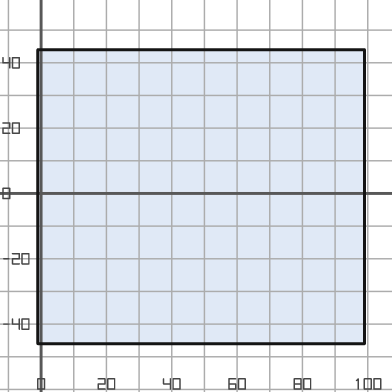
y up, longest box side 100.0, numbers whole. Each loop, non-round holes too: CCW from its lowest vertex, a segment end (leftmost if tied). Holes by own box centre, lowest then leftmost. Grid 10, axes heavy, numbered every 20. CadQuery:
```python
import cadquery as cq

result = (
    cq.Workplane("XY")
    .moveTo(-1.0, -46.0)
    .lineTo(99.0, -46.0)
    .lineTo(99.0, 44.0)
    .lineTo(-1.0, 44.0)
    .close()
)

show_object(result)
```